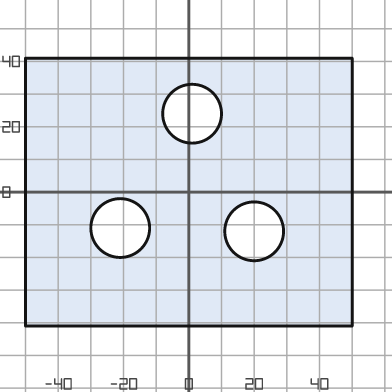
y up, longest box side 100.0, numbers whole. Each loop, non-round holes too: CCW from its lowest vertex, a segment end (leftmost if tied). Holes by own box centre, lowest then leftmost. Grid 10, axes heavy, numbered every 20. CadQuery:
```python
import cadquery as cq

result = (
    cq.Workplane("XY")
    .moveTo(-50.0, -41.0)
    .lineTo(50.0, -41.0)
    .lineTo(50.0, 41.0)
    .lineTo(-50.0, 41.0)
    .close()
    .moveTo(20.0, -12.0)
    .circle(9.0)
    .moveTo(-21.0, -11.0)
    .circle(9.0)
    .moveTo(1.0, 24.0)
    .circle(9.0)
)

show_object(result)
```